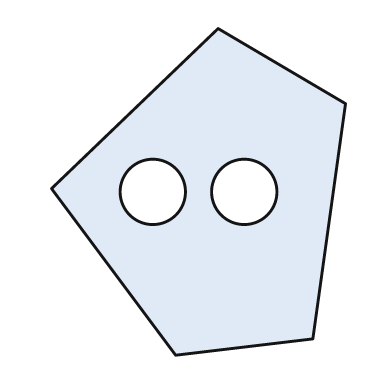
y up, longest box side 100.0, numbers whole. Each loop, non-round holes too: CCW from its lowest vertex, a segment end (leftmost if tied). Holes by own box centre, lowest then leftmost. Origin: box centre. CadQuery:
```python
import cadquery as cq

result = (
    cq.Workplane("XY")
    .moveTo(-7.0, -50.0)
    .lineTo(35.0, -45.0)
    .lineTo(45.0, 27.0)
    .lineTo(6.0, 50.0)
    .lineTo(-45.0, 1.0)
    .close()
    .moveTo(-14.0, 0.0)
    .circle(10.0)
    .moveTo(14.0, 0.0)
    .circle(10.0)
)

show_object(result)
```